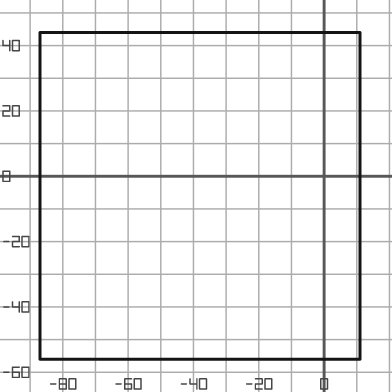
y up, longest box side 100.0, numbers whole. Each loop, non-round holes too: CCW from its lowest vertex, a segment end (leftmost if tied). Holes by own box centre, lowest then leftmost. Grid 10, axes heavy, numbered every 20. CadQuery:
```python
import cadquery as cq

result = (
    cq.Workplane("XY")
    .moveTo(-87.0, -56.0)
    .lineTo(11.0, -56.0)
    .lineTo(11.0, 44.0)
    .lineTo(-87.0, 44.0)
    .close()
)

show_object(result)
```